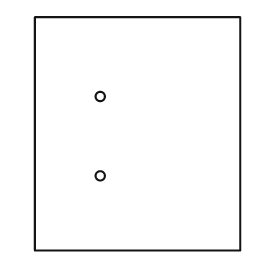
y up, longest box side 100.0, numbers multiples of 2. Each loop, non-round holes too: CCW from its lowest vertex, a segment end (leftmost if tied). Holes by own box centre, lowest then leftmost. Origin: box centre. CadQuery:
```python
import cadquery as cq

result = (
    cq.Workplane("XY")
    .moveTo(-44.0, -50.0)
    .lineTo(44.0, -50.0)
    .lineTo(44.0, 50.0)
    .lineTo(-44.0, 50.0)
    .close()
    .moveTo(-16.0, -18.0)
    .circle(2.0)
    .moveTo(-16.0, 16.0)
    .circle(2.0)
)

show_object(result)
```